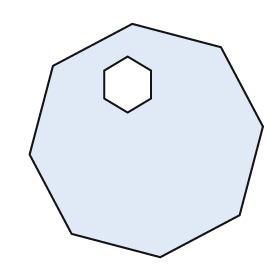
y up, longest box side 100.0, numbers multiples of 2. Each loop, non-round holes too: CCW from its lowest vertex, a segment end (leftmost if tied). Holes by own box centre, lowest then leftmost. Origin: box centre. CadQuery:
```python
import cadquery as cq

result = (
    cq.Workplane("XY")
    .moveTo(6.0, -50.0)
    .lineTo(40.0, -32.0)
    .lineTo(50.0, 6.0)
    .lineTo(32.0, 40.0)
    .lineTo(-6.0, 50.0)
    .lineTo(-40.0, 32.0)
    .lineTo(-50.0, -6.0)
    .lineTo(-32.0, -40.0)
    .close()
    .moveTo(-8.0, 12.0)
    .lineTo(2.0, 18.0)
    .lineTo(2.0, 30.0)
    .lineTo(-8.0, 36.0)
    .lineTo(-18.0, 30.0)
    .lineTo(-18.0, 18.0)
    .close()
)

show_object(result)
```